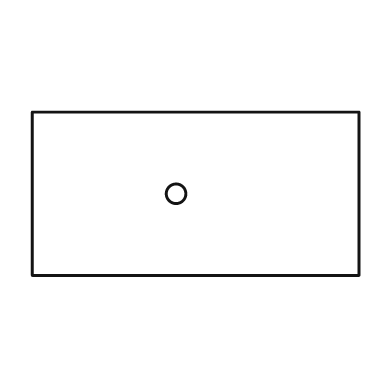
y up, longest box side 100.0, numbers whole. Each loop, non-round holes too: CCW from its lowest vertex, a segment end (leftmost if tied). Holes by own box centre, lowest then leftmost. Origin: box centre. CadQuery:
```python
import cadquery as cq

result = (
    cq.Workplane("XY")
    .moveTo(-50.0, -25.0)
    .lineTo(50.0, -25.0)
    .lineTo(50.0, 25.0)
    .lineTo(-50.0, 25.0)
    .close()
    .moveTo(-6.0, 0.0)
    .circle(3.0)
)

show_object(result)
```